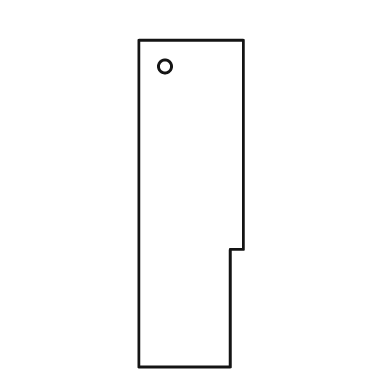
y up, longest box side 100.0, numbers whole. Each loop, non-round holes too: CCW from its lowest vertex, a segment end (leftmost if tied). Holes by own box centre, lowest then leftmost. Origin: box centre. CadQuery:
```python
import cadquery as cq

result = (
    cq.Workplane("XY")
    .moveTo(-16.0, -50.0)
    .lineTo(12.0, -50.0)
    .lineTo(12.0, -14.0)
    .lineTo(16.0, -14.0)
    .lineTo(16.0, 50.0)
    .lineTo(-16.0, 50.0)
    .close()
    .moveTo(-8.0, 42.0)
    .circle(2.0)
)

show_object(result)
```